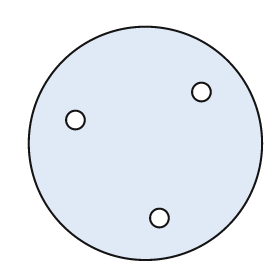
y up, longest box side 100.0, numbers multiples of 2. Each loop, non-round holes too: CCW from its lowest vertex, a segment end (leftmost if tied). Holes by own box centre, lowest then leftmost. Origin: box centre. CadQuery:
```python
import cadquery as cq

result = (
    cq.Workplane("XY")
    .moveTo(0.0, 0.0)
    .circle(50.0)
    .moveTo(6.0, -32.0)
    .circle(4.0)
    .moveTo(-30.0, 10.0)
    .circle(4.0)
    .moveTo(24.0, 22.0)
    .circle(4.0)
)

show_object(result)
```